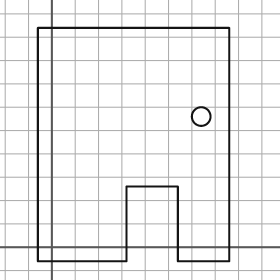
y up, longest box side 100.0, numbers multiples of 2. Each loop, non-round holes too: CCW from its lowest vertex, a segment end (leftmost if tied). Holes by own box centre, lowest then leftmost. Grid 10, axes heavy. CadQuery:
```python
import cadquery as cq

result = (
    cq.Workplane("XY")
    .moveTo(-6.0, -6.0)
    .lineTo(32.0, -6.0)
    .lineTo(32.0, 26.0)
    .lineTo(54.0, 26.0)
    .lineTo(54.0, -6.0)
    .lineTo(76.0, -6.0)
    .lineTo(76.0, 94.0)
    .lineTo(-6.0, 94.0)
    .close()
    .moveTo(64.0, 56.0)
    .circle(4.0)
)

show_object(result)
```